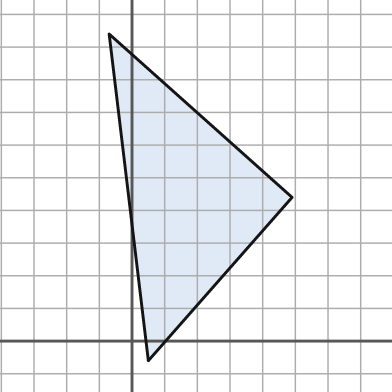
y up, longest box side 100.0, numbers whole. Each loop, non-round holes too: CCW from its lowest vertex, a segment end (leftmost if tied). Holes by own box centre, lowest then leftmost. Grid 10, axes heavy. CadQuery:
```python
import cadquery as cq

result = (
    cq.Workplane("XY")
    .moveTo(5.0, -6.0)
    .lineTo(49.0, 44.0)
    .lineTo(-7.0, 94.0)
    .close()
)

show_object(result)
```